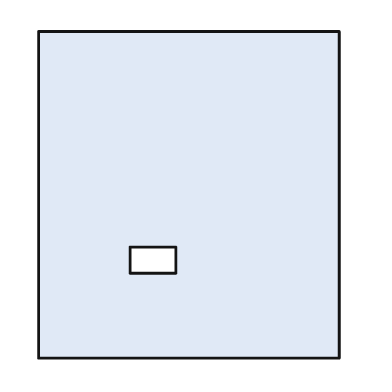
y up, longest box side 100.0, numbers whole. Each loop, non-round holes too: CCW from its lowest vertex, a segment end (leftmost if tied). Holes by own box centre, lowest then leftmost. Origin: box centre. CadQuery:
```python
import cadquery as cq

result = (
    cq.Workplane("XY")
    .moveTo(-46.0, -50.0)
    .lineTo(46.0, -50.0)
    .lineTo(46.0, 50.0)
    .lineTo(-46.0, 50.0)
    .close()
    .moveTo(-18.0, -24.0)
    .lineTo(-4.0, -24.0)
    .lineTo(-4.0, -16.0)
    .lineTo(-18.0, -16.0)
    .close()
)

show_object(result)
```